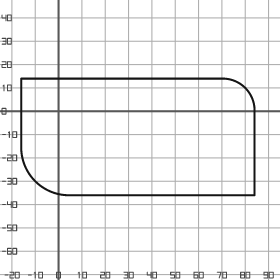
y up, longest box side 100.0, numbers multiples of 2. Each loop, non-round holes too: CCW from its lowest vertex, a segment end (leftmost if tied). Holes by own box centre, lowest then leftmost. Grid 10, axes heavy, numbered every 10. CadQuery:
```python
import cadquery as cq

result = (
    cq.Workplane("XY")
    .moveTo(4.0, -36.0)
    .lineTo(84.0, -36.0)
    .lineTo(84.0, 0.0)
    .threePointArc((80.0, 10.0), (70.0, 14.0))
    .lineTo(-16.0, 14.0)
    .lineTo(-16.0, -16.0)
    .threePointArc((-10.0, -30.0), (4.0, -36.0))
    .close()
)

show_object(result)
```